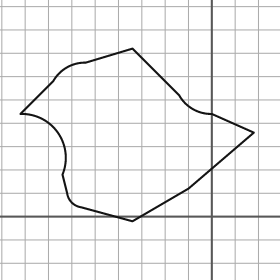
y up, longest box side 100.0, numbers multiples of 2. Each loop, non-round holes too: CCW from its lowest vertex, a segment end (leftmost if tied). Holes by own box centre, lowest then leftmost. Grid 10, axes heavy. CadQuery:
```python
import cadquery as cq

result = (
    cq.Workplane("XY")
    .moveTo(-34.0, -2.0)
    .lineTo(-10.0, 12.0)
    .lineTo(18.0, 36.0)
    .lineTo(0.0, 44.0)
    .threePointArc((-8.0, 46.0), (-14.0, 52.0))
    .lineTo(-34.0, 72.0)
    .lineTo(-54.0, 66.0)
    .threePointArc((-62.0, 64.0), (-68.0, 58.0))
    .lineTo(-82.0, 44.0)
    .threePointArc((-66.0, 36.0), (-64.0, 18.0))
    .lineTo(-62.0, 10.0)
    .threePointArc((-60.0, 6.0), (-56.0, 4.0))
    .close()
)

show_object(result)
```